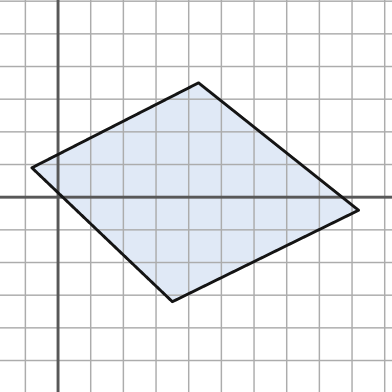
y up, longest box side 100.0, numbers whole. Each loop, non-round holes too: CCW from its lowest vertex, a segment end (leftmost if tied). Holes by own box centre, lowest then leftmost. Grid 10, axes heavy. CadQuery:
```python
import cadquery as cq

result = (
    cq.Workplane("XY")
    .moveTo(35.0, -32.0)
    .lineTo(92.0, -4.0)
    .lineTo(43.0, 35.0)
    .lineTo(-8.0, 9.0)
    .close()
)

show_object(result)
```